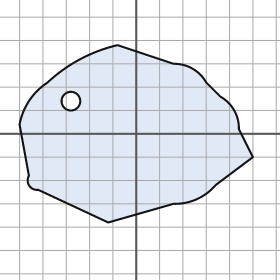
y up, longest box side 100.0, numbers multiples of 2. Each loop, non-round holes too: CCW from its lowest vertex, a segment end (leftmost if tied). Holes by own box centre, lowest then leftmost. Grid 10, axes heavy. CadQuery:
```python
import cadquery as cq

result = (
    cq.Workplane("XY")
    .moveTo(-12.0, -38.0)
    .lineTo(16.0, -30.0)
    .threePointArc((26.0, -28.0), (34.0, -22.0))
    .lineTo(50.0, -10.0)
    .lineTo(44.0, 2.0)
    .threePointArc((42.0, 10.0), (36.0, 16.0))
    .lineTo(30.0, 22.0)
    .threePointArc((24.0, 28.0), (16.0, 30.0))
    .lineTo(-8.0, 38.0)
    .threePointArc((-24.0, 32.0), (-38.0, 22.0))
    .threePointArc((-46.0, 14.0), (-50.0, 4.0))
    .lineTo(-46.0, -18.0)
    .threePointArc((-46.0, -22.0), (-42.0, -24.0))
    .close()
    .moveTo(-28.0, 14.0)
    .circle(4.0)
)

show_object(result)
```